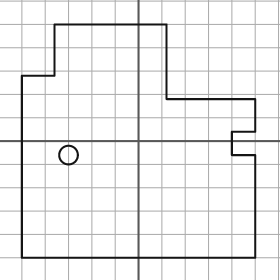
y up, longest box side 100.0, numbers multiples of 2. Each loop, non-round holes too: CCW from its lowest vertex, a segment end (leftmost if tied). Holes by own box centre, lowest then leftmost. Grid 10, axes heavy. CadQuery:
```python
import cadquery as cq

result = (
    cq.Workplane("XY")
    .moveTo(-50.0, -50.0)
    .lineTo(50.0, -50.0)
    .lineTo(50.0, -6.0)
    .lineTo(40.0, -6.0)
    .lineTo(40.0, 4.0)
    .lineTo(50.0, 4.0)
    .lineTo(50.0, 18.0)
    .lineTo(12.0, 18.0)
    .lineTo(12.0, 50.0)
    .lineTo(-36.0, 50.0)
    .lineTo(-36.0, 28.0)
    .lineTo(-50.0, 28.0)
    .close()
    .moveTo(-30.0, -6.0)
    .circle(4.0)
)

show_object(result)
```